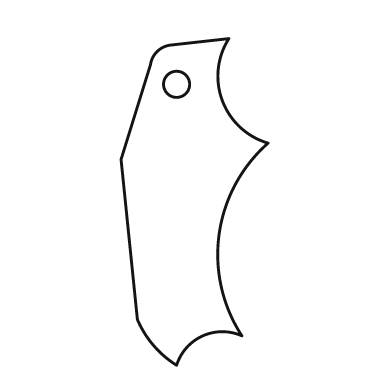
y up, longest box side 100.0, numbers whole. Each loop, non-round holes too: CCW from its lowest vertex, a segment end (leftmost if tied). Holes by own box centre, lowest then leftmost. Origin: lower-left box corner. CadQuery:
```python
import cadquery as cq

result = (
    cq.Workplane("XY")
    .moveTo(17.0, 0.0)
    .threePointArc((25.0, 9.0), (37.0, 9.0))
    .threePointArc((30.0, 40.0), (45.0, 68.0))
    .threePointArc((31.0, 81.0), (33.0, 100.0))
    .lineTo(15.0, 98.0)
    .threePointArc((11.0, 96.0), (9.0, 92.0))
    .lineTo(0.0, 63.0)
    .lineTo(5.0, 14.0)
    .threePointArc((10.0, 6.0), (17.0, 0.0))
    .close()
    .moveTo(17.0, 86.0)
    .circle(4.0)
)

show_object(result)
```